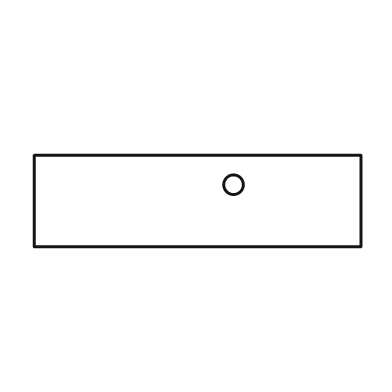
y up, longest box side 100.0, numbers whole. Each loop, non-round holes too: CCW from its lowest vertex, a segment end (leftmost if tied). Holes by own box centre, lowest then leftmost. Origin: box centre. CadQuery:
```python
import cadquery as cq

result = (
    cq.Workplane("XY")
    .moveTo(-50.0, -14.0)
    .lineTo(50.0, -14.0)
    .lineTo(50.0, 14.0)
    .lineTo(-50.0, 14.0)
    .close()
    .moveTo(11.0, 5.0)
    .circle(3.0)
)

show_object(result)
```